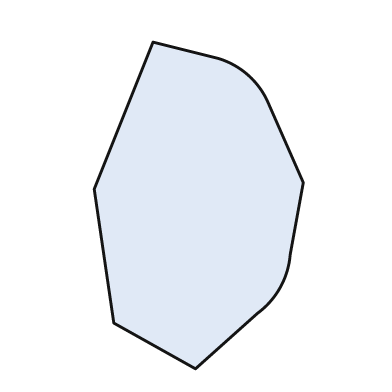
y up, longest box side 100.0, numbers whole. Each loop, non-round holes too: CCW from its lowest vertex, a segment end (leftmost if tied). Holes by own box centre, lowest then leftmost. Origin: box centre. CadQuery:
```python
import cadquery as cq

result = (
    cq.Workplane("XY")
    .moveTo(-1.0, -50.0)
    .lineTo(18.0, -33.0)
    .threePointArc((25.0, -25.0), (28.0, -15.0))
    .lineTo(32.0, 7.0)
    .lineTo(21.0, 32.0)
    .threePointArc((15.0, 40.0), (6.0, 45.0))
    .lineTo(-14.0, 50.0)
    .lineTo(-32.0, 5.0)
    .lineTo(-26.0, -36.0)
    .close()
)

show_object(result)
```